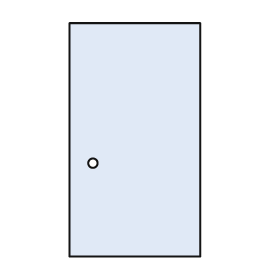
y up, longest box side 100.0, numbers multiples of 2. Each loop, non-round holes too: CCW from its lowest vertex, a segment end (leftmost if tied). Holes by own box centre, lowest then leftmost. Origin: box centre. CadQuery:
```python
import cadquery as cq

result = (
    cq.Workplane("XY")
    .moveTo(-28.0, -50.0)
    .lineTo(28.0, -50.0)
    .lineTo(28.0, 50.0)
    .lineTo(-28.0, 50.0)
    .close()
    .moveTo(-18.0, -10.0)
    .circle(2.0)
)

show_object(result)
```